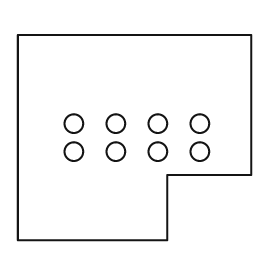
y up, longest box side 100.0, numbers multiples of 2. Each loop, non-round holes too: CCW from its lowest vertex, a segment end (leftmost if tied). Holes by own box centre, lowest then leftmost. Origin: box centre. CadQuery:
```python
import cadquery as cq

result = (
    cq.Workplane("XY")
    .moveTo(-50.0, -44.0)
    .lineTo(14.0, -44.0)
    .lineTo(14.0, -16.0)
    .lineTo(50.0, -16.0)
    .lineTo(50.0, 44.0)
    .lineTo(-50.0, 44.0)
    .close()
    .moveTo(-26.0, -6.0)
    .circle(4.0)
    .moveTo(-8.0, -6.0)
    .circle(4.0)
    .moveTo(10.0, -6.0)
    .circle(4.0)
    .moveTo(28.0, -6.0)
    .circle(4.0)
    .moveTo(-26.0, 6.0)
    .circle(4.0)
    .moveTo(-8.0, 6.0)
    .circle(4.0)
    .moveTo(10.0, 6.0)
    .circle(4.0)
    .moveTo(28.0, 6.0)
    .circle(4.0)
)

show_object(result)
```